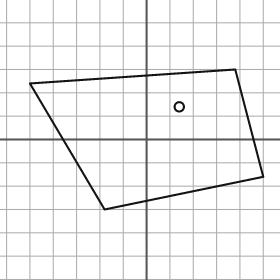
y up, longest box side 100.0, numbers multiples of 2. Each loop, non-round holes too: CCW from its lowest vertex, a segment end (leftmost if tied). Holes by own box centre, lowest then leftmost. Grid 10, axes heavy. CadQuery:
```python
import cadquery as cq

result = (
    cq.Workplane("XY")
    .moveTo(-18.0, -30.0)
    .lineTo(50.0, -16.0)
    .lineTo(38.0, 30.0)
    .lineTo(-50.0, 24.0)
    .close()
    .moveTo(14.0, 14.0)
    .circle(2.0)
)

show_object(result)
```